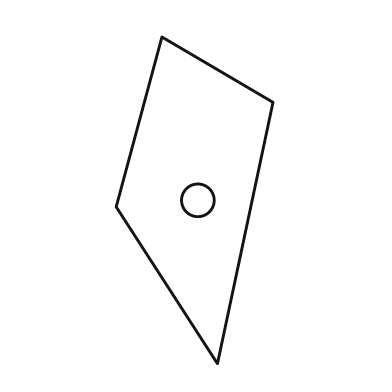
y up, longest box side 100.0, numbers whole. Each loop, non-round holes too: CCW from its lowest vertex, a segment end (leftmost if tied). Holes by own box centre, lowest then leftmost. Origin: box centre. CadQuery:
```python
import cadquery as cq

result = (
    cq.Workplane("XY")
    .moveTo(7.0, -50.0)
    .lineTo(24.0, 30.0)
    .lineTo(-10.0, 50.0)
    .lineTo(-24.0, -2.0)
    .close()
    .moveTo(1.0, 0.0)
    .circle(5.0)
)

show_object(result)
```